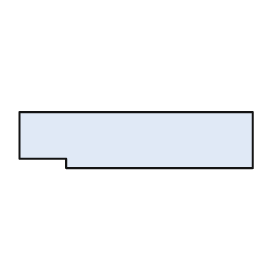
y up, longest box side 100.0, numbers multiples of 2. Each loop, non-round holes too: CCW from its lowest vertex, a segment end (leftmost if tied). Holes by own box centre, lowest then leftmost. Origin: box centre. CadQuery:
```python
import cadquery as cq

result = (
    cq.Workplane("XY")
    .moveTo(-30.0, -12.0)
    .lineTo(50.0, -12.0)
    .lineTo(50.0, 12.0)
    .lineTo(-50.0, 12.0)
    .lineTo(-50.0, -8.0)
    .lineTo(-30.0, -8.0)
    .close()
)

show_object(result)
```